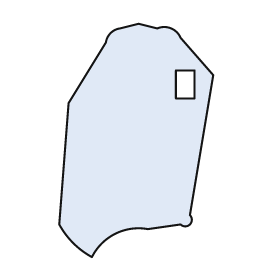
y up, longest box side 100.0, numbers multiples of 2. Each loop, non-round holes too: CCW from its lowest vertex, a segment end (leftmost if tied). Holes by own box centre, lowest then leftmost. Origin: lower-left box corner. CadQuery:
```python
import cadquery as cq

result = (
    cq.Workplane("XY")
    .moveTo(14.0, 0.0)
    .threePointArc((24.0, 10.0), (38.0, 12.0))
    .lineTo(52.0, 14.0)
    .threePointArc((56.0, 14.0), (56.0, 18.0))
    .lineTo(66.0, 78.0)
    .lineTo(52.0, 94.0)
    .threePointArc((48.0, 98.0), (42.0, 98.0))
    .lineTo(34.0, 100.0)
    .lineTo(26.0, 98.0)
    .threePointArc((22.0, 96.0), (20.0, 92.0))
    .lineTo(4.0, 66.0)
    .lineTo(0.0, 14.0)
    .threePointArc((6.0, 6.0), (14.0, 0.0))
    .close()
    .moveTo(50.0, 68.0)
    .lineTo(58.0, 68.0)
    .lineTo(58.0, 80.0)
    .lineTo(50.0, 80.0)
    .close()
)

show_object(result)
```